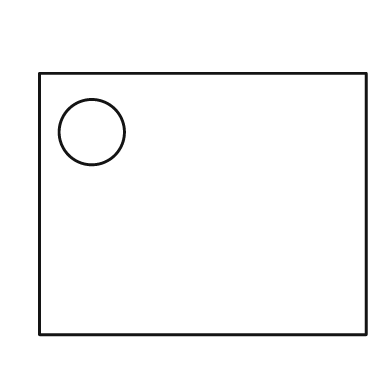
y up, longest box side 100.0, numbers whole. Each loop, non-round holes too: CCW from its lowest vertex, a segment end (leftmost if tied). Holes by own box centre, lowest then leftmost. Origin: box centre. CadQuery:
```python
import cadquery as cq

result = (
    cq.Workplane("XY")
    .moveTo(-50.0, -40.0)
    .lineTo(50.0, -40.0)
    .lineTo(50.0, 40.0)
    .lineTo(-50.0, 40.0)
    .close()
    .moveTo(-34.0, 22.0)
    .circle(10.0)
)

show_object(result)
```